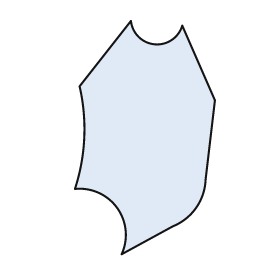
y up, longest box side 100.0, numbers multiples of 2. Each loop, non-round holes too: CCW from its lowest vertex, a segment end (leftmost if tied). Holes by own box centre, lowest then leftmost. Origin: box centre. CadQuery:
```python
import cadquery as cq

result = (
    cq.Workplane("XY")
    .moveTo(-10.0, -50.0)
    .lineTo(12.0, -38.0)
    .threePointArc((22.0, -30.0), (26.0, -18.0))
    .lineTo(30.0, 16.0)
    .lineTo(16.0, 48.0)
    .threePointArc((4.0, 40.0), (-6.0, 50.0))
    .lineTo(-28.0, 22.0)
    .threePointArc((-26.0, 0.0), (-30.0, -22.0))
    .threePointArc((-12.0, -30.0), (-10.0, -50.0))
    .close()
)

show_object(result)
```